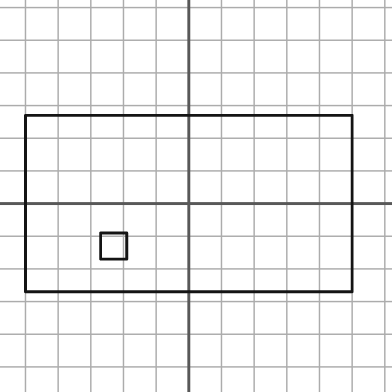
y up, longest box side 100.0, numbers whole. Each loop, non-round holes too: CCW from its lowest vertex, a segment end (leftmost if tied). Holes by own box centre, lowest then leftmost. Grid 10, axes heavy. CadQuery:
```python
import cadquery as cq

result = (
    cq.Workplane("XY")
    .moveTo(-50.0, -27.0)
    .lineTo(50.0, -27.0)
    .lineTo(50.0, 27.0)
    .lineTo(-50.0, 27.0)
    .close()
    .moveTo(-27.0, -17.0)
    .lineTo(-19.0, -17.0)
    .lineTo(-19.0, -9.0)
    .lineTo(-27.0, -9.0)
    .close()
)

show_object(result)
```